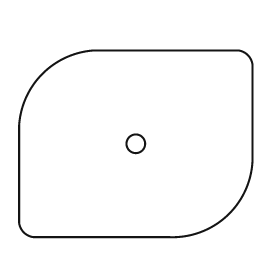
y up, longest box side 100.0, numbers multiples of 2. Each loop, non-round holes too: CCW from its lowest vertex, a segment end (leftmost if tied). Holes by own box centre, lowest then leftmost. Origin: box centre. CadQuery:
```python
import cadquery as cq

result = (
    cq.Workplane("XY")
    .moveTo(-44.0, -40.0)
    .lineTo(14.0, -40.0)
    .threePointArc((40.0, -30.0), (50.0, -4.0))
    .lineTo(50.0, 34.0)
    .threePointArc((48.0, 38.0), (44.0, 40.0))
    .lineTo(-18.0, 40.0)
    .threePointArc((-40.0, 30.0), (-50.0, 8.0))
    .lineTo(-50.0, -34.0)
    .threePointArc((-48.0, -38.0), (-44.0, -40.0))
    .close()
    .moveTo(0.0, 0.0)
    .circle(4.0)
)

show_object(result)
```